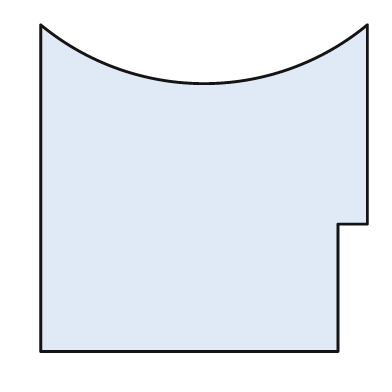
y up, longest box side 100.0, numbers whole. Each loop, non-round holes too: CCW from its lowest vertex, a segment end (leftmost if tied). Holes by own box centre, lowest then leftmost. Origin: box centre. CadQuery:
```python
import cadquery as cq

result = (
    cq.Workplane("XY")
    .moveTo(-50.0, -50.0)
    .lineTo(41.0, -50.0)
    .lineTo(41.0, -11.0)
    .lineTo(50.0, -11.0)
    .lineTo(50.0, 50.0)
    .threePointArc((0.0, 32.0), (-50.0, 50.0))
    .close()
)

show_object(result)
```